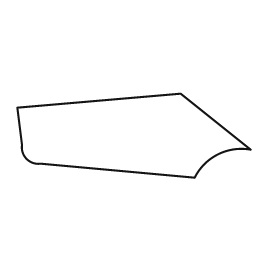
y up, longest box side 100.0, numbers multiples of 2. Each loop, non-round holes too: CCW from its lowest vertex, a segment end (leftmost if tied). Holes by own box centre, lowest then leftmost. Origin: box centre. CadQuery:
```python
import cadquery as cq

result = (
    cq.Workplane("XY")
    .moveTo(26.0, -18.0)
    .threePointArc((36.0, -8.0), (50.0, -6.0))
    .lineTo(20.0, 18.0)
    .lineTo(-50.0, 12.0)
    .lineTo(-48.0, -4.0)
    .threePointArc((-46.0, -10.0), (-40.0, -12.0))
    .close()
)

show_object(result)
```